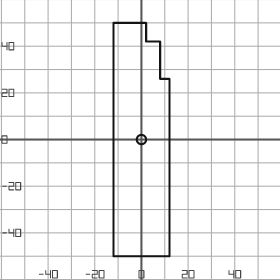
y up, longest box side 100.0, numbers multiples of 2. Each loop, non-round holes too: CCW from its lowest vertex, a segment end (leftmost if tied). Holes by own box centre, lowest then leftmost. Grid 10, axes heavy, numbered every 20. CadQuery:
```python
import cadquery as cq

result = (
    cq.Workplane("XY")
    .moveTo(-12.0, -50.0)
    .lineTo(12.0, -50.0)
    .lineTo(12.0, 26.0)
    .lineTo(8.0, 26.0)
    .lineTo(8.0, 42.0)
    .lineTo(2.0, 42.0)
    .lineTo(2.0, 50.0)
    .lineTo(-12.0, 50.0)
    .close()
    .moveTo(0.0, 0.0)
    .circle(2.0)
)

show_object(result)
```